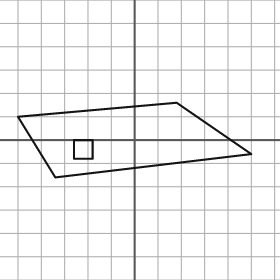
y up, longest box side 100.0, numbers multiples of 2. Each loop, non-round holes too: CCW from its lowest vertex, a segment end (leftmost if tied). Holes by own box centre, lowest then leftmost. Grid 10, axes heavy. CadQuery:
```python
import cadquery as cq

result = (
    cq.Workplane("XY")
    .moveTo(-34.0, -16.0)
    .lineTo(50.0, -6.0)
    .lineTo(18.0, 16.0)
    .lineTo(-50.0, 10.0)
    .close()
    .moveTo(-26.0, -8.0)
    .lineTo(-18.0, -8.0)
    .lineTo(-18.0, 0.0)
    .lineTo(-26.0, 0.0)
    .close()
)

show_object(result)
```